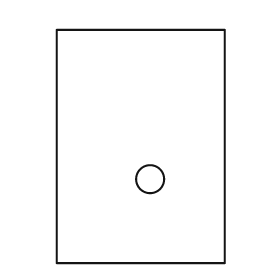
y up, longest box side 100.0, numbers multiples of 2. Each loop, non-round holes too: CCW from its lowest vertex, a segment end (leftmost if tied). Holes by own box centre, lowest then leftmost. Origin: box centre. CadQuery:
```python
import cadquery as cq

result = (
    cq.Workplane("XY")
    .moveTo(-36.0, -50.0)
    .lineTo(36.0, -50.0)
    .lineTo(36.0, 50.0)
    .lineTo(-36.0, 50.0)
    .close()
    .moveTo(4.0, -14.0)
    .circle(6.0)
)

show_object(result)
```